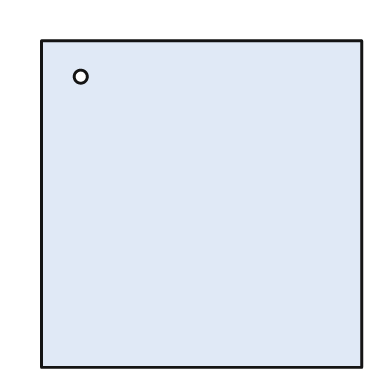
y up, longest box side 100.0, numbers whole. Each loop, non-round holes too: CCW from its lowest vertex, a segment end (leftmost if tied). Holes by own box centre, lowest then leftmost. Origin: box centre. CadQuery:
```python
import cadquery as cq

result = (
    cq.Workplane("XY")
    .moveTo(-49.0, -50.0)
    .lineTo(49.0, -50.0)
    .lineTo(49.0, 50.0)
    .lineTo(-49.0, 50.0)
    .close()
    .moveTo(-37.0, 39.0)
    .circle(2.0)
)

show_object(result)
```